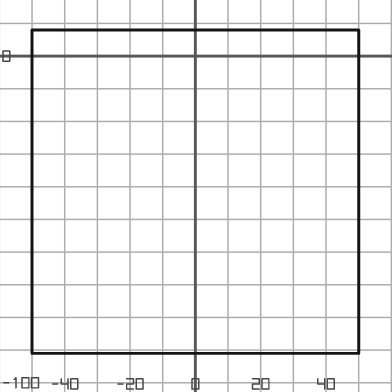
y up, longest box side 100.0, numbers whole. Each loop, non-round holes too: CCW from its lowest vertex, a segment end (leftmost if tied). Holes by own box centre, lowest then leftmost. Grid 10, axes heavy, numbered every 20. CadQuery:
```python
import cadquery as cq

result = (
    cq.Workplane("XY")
    .moveTo(-50.0, -91.0)
    .lineTo(50.0, -91.0)
    .lineTo(50.0, 8.0)
    .lineTo(-50.0, 8.0)
    .close()
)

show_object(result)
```